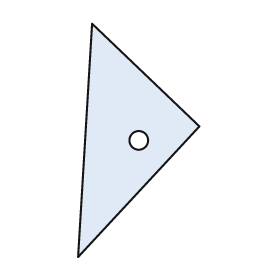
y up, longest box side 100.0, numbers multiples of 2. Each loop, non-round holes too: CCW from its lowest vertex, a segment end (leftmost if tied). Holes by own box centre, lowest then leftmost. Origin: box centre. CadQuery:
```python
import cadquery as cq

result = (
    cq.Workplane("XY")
    .moveTo(-26.0, -50.0)
    .lineTo(26.0, 6.0)
    .lineTo(-20.0, 50.0)
    .close()
    .moveTo(0.0, 0.0)
    .circle(4.0)
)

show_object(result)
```